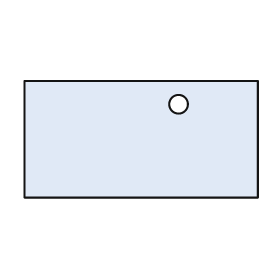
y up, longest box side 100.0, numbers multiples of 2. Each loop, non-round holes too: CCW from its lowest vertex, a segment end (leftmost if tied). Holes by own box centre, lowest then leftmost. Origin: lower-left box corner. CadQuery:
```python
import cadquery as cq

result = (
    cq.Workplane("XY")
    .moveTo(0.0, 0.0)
    .lineTo(100.0, 0.0)
    .lineTo(100.0, 50.0)
    .lineTo(0.0, 50.0)
    .close()
    .moveTo(66.0, 40.0)
    .circle(4.0)
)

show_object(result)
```